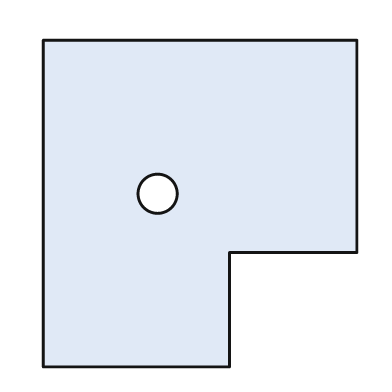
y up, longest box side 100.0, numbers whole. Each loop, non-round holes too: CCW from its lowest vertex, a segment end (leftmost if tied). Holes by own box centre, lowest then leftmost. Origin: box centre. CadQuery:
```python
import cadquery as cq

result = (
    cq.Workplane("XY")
    .moveTo(-48.0, -50.0)
    .lineTo(9.0, -50.0)
    .lineTo(9.0, -15.0)
    .lineTo(48.0, -15.0)
    .lineTo(48.0, 50.0)
    .lineTo(-48.0, 50.0)
    .close()
    .moveTo(-13.0, 3.0)
    .circle(6.0)
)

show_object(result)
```